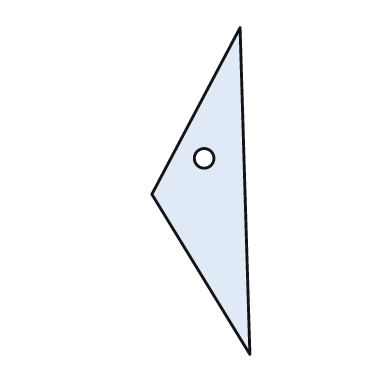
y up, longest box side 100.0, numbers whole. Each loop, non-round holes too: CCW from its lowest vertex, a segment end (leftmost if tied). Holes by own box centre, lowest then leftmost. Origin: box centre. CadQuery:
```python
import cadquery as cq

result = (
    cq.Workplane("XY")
    .moveTo(15.0, -50.0)
    .lineTo(12.0, 50.0)
    .lineTo(-15.0, -1.0)
    .close()
    .moveTo(1.0, 10.0)
    .circle(3.0)
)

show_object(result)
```